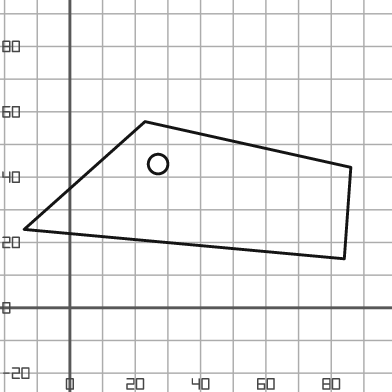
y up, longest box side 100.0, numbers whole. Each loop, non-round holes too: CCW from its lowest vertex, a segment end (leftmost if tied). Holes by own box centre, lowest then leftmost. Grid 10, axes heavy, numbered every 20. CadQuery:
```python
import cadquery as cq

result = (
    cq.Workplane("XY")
    .moveTo(84.0, 15.0)
    .lineTo(86.0, 43.0)
    .lineTo(23.0, 57.0)
    .lineTo(-14.0, 24.0)
    .close()
    .moveTo(27.0, 44.0)
    .circle(3.0)
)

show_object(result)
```